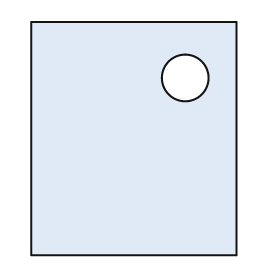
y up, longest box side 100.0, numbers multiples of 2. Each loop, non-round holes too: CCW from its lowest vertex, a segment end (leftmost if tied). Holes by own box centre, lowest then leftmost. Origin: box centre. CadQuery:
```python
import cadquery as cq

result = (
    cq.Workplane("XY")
    .moveTo(-44.0, -50.0)
    .lineTo(44.0, -50.0)
    .lineTo(44.0, 50.0)
    .lineTo(-44.0, 50.0)
    .close()
    .moveTo(22.0, 26.0)
    .circle(10.0)
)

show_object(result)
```